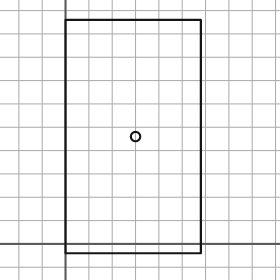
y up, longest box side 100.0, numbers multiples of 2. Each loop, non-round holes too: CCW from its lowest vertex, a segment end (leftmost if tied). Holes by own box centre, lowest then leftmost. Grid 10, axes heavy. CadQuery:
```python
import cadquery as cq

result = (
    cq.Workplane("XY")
    .moveTo(0.0, -4.0)
    .lineTo(58.0, -4.0)
    .lineTo(58.0, 96.0)
    .lineTo(0.0, 96.0)
    .close()
    .moveTo(30.0, 46.0)
    .circle(2.0)
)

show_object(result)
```